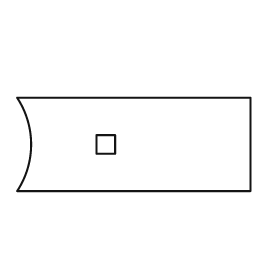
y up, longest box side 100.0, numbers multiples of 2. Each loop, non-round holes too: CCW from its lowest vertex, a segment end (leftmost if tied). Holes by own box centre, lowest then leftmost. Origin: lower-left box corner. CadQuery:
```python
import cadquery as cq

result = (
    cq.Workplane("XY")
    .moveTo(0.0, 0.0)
    .lineTo(100.0, 0.0)
    .lineTo(100.0, 40.0)
    .lineTo(0.0, 40.0)
    .threePointArc((6.0, 20.0), (0.0, 0.0))
    .close()
    .moveTo(34.0, 16.0)
    .lineTo(42.0, 16.0)
    .lineTo(42.0, 24.0)
    .lineTo(34.0, 24.0)
    .close()
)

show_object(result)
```